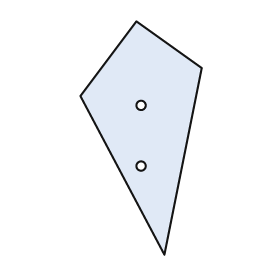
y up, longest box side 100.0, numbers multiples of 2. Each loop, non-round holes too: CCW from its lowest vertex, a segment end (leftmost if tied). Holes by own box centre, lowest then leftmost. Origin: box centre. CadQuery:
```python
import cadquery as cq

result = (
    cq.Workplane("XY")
    .moveTo(10.0, -50.0)
    .lineTo(26.0, 30.0)
    .lineTo(-2.0, 50.0)
    .lineTo(-26.0, 18.0)
    .close()
    .moveTo(0.0, -12.0)
    .circle(2.0)
    .moveTo(0.0, 14.0)
    .circle(2.0)
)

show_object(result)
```